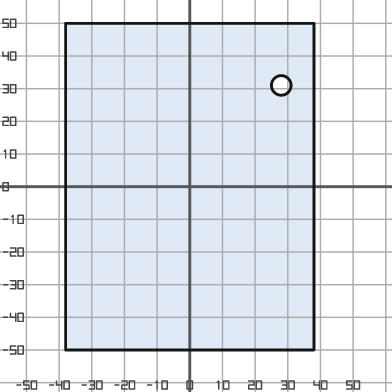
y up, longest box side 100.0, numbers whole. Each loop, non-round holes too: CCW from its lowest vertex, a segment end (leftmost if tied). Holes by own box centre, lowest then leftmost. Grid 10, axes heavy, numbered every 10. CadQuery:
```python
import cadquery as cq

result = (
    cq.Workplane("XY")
    .moveTo(-38.0, -50.0)
    .lineTo(38.0, -50.0)
    .lineTo(38.0, 50.0)
    .lineTo(-38.0, 50.0)
    .close()
    .moveTo(28.0, 31.0)
    .circle(3.0)
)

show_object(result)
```